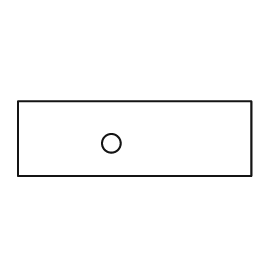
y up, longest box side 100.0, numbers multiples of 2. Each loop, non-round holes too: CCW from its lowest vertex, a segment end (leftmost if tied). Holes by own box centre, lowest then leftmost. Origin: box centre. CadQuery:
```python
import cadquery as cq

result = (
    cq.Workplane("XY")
    .moveTo(-50.0, -16.0)
    .lineTo(50.0, -16.0)
    .lineTo(50.0, 16.0)
    .lineTo(-50.0, 16.0)
    .close()
    .moveTo(-10.0, -2.0)
    .circle(4.0)
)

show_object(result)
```